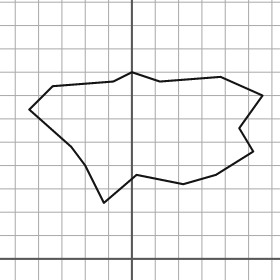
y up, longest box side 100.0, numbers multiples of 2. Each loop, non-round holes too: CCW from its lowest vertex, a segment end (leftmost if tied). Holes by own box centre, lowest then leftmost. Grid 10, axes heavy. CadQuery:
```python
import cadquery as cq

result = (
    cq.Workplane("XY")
    .moveTo(-12.0, 24.0)
    .lineTo(2.0, 36.0)
    .lineTo(22.0, 32.0)
    .lineTo(36.0, 36.0)
    .lineTo(52.0, 46.0)
    .lineTo(46.0, 56.0)
    .lineTo(56.0, 70.0)
    .lineTo(38.0, 78.0)
    .lineTo(12.0, 76.0)
    .lineTo(0.0, 80.0)
    .lineTo(-8.0, 76.0)
    .lineTo(-34.0, 74.0)
    .lineTo(-44.0, 64.0)
    .lineTo(-26.0, 48.0)
    .lineTo(-20.0, 40.0)
    .close()
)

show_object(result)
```